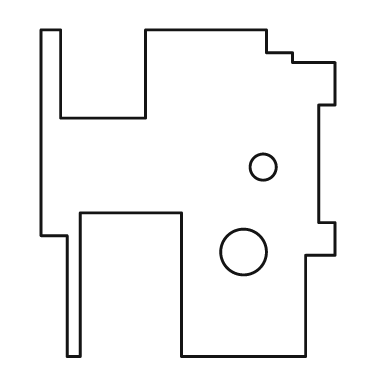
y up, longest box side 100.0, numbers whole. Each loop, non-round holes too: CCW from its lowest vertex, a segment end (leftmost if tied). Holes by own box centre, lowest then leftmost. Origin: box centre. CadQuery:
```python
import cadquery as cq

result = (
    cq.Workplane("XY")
    .moveTo(-37.0, -50.0)
    .lineTo(-33.0, -50.0)
    .lineTo(-33.0, -6.0)
    .lineTo(-2.0, -6.0)
    .lineTo(-2.0, -50.0)
    .lineTo(36.0, -50.0)
    .lineTo(36.0, -19.0)
    .lineTo(45.0, -19.0)
    .lineTo(45.0, -9.0)
    .lineTo(40.0, -9.0)
    .lineTo(40.0, 27.0)
    .lineTo(45.0, 27.0)
    .lineTo(45.0, 40.0)
    .lineTo(32.0, 40.0)
    .lineTo(32.0, 43.0)
    .lineTo(24.0, 43.0)
    .lineTo(24.0, 50.0)
    .lineTo(-13.0, 50.0)
    .lineTo(-13.0, 23.0)
    .lineTo(-39.0, 23.0)
    .lineTo(-39.0, 50.0)
    .lineTo(-45.0, 50.0)
    .lineTo(-45.0, -13.0)
    .lineTo(-37.0, -13.0)
    .close()
    .moveTo(17.0, -18.0)
    .circle(7.0)
    .moveTo(23.0, 8.0)
    .circle(4.0)
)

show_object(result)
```